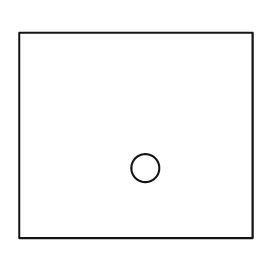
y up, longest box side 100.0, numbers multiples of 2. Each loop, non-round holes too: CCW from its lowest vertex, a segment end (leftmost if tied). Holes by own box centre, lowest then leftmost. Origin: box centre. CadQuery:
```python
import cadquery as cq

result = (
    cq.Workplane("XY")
    .moveTo(-50.0, -44.0)
    .lineTo(50.0, -44.0)
    .lineTo(50.0, 44.0)
    .lineTo(-50.0, 44.0)
    .close()
    .moveTo(4.0, -14.0)
    .circle(6.0)
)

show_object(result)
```